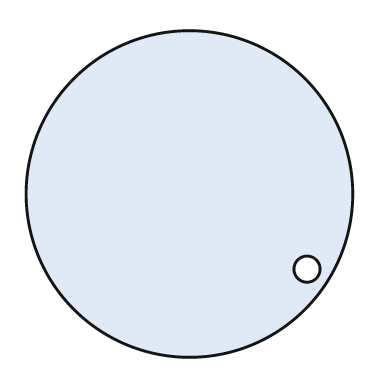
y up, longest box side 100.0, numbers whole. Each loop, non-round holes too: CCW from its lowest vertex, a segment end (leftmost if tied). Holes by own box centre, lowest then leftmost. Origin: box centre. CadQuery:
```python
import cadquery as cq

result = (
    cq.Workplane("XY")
    .moveTo(0.0, 0.0)
    .circle(50.0)
    .moveTo(36.0, -23.0)
    .circle(4.0)
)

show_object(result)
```